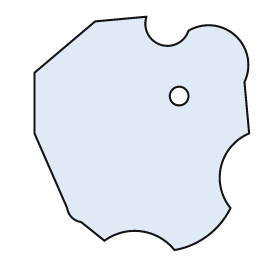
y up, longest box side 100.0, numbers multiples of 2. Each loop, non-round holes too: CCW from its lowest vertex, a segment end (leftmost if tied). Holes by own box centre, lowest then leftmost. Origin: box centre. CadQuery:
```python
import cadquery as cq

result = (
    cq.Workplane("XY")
    .moveTo(14.0, -50.0)
    .threePointArc((28.0, -44.0), (38.0, -32.0))
    .threePointArc((34.0, -14.0), (46.0, 0.0))
    .lineTo(44.0, 22.0)
    .threePointArc((40.0, 42.0), (20.0, 44.0))
    .threePointArc((8.0, 38.0), (2.0, 50.0))
    .lineTo(-20.0, 48.0)
    .lineTo(-46.0, 26.0)
    .lineTo(-46.0, 0.0)
    .lineTo(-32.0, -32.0)
    .threePointArc((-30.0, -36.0), (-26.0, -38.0))
    .lineTo(-16.0, -46.0)
    .threePointArc((0.0, -42.0), (14.0, -50.0))
    .close()
    .moveTo(16.0, 16.0)
    .circle(4.0)
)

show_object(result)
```